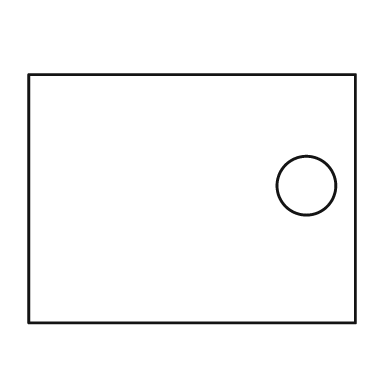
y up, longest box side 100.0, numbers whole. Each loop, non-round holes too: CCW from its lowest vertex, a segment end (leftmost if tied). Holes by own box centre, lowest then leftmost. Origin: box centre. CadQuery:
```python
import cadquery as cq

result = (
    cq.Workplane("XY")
    .moveTo(-50.0, -38.0)
    .lineTo(50.0, -38.0)
    .lineTo(50.0, 38.0)
    .lineTo(-50.0, 38.0)
    .close()
    .moveTo(35.0, 4.0)
    .circle(9.0)
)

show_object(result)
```